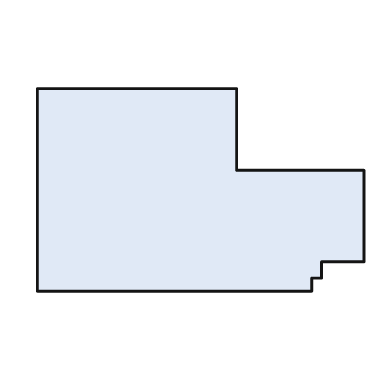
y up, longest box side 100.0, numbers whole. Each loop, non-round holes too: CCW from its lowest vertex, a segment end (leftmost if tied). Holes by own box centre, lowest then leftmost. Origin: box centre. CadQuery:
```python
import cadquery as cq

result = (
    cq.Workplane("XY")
    .moveTo(-50.0, -31.0)
    .lineTo(34.0, -31.0)
    .lineTo(34.0, -27.0)
    .lineTo(37.0, -27.0)
    .lineTo(37.0, -22.0)
    .lineTo(50.0, -22.0)
    .lineTo(50.0, 6.0)
    .lineTo(11.0, 6.0)
    .lineTo(11.0, 31.0)
    .lineTo(-50.0, 31.0)
    .close()
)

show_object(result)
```